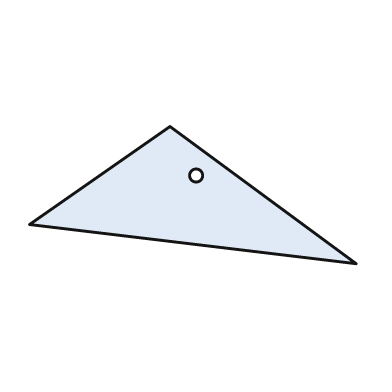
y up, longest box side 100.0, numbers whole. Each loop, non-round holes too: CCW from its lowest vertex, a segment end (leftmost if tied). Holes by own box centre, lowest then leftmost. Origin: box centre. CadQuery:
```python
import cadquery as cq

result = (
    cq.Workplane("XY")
    .moveTo(50.0, -21.0)
    .lineTo(-7.0, 21.0)
    .lineTo(-50.0, -9.0)
    .close()
    .moveTo(1.0, 6.0)
    .circle(2.0)
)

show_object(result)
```